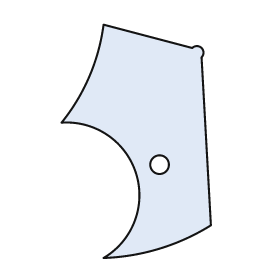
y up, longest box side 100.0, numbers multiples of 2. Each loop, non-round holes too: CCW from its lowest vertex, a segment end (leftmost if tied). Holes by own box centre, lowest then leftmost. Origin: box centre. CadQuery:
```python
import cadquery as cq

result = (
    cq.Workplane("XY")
    .moveTo(-14.0, -50.0)
    .threePointArc((10.0, -46.0), (32.0, -36.0))
    .lineTo(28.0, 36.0)
    .threePointArc((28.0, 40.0), (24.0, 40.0))
    .lineTo(-14.0, 50.0)
    .threePointArc((-20.0, 28.0), (-32.0, 8.0))
    .threePointArc((0.0, -14.0), (-14.0, -50.0))
    .close()
    .moveTo(10.0, -10.0)
    .circle(4.0)
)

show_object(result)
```